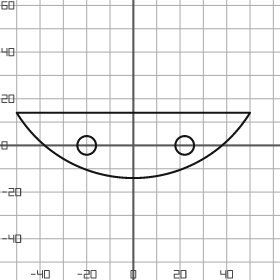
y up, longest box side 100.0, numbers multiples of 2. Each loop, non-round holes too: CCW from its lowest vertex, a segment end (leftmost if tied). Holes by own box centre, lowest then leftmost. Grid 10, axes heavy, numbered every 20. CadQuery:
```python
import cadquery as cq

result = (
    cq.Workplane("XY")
    .moveTo(-50.0, 14.0)
    .threePointArc((0.0, -14.0), (50.0, 14.0))
    .close()
    .moveTo(-20.0, 0.0)
    .circle(4.0)
    .moveTo(22.0, 0.0)
    .circle(4.0)
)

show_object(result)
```